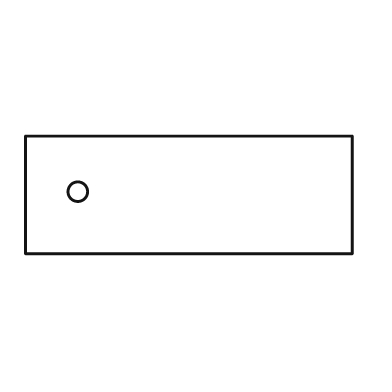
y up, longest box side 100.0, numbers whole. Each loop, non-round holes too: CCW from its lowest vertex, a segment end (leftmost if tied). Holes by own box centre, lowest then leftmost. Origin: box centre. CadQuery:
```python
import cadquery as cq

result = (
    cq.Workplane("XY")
    .moveTo(-50.0, -18.0)
    .lineTo(50.0, -18.0)
    .lineTo(50.0, 18.0)
    .lineTo(-50.0, 18.0)
    .close()
    .moveTo(-34.0, 1.0)
    .circle(3.0)
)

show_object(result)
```